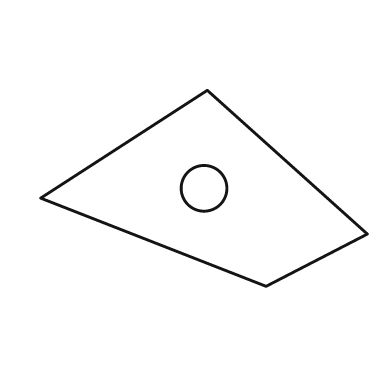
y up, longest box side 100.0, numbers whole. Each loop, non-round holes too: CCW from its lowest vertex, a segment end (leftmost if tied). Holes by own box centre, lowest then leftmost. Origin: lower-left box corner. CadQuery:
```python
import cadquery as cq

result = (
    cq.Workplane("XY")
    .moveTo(69.0, 0.0)
    .lineTo(100.0, 16.0)
    .lineTo(51.0, 60.0)
    .lineTo(0.0, 27.0)
    .close()
    .moveTo(50.0, 30.0)
    .circle(7.0)
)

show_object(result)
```